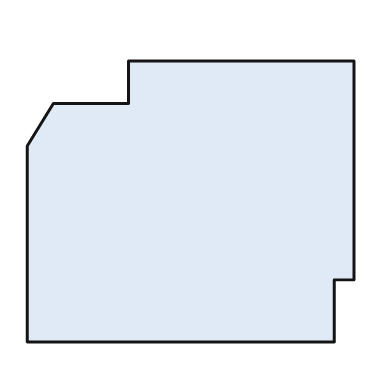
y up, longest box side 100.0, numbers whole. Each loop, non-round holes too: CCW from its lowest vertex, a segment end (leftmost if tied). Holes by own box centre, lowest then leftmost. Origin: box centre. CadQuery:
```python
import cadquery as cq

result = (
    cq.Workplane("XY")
    .moveTo(-50.0, -43.0)
    .lineTo(44.0, -43.0)
    .lineTo(44.0, -24.0)
    .lineTo(50.0, -24.0)
    .lineTo(50.0, 43.0)
    .lineTo(-19.0, 43.0)
    .lineTo(-19.0, 30.0)
    .lineTo(-42.0, 30.0)
    .lineTo(-50.0, 17.0)
    .close()
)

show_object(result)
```